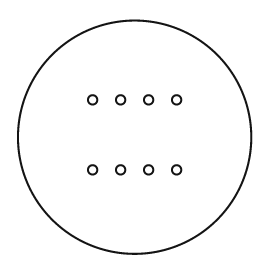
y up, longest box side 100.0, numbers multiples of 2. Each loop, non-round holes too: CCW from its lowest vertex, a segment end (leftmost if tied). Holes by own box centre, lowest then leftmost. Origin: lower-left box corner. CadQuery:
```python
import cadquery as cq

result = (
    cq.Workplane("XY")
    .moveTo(50.0, 50.0)
    .circle(50.0)
    .moveTo(32.0, 36.0)
    .circle(2.0)
    .moveTo(44.0, 36.0)
    .circle(2.0)
    .moveTo(56.0, 36.0)
    .circle(2.0)
    .moveTo(68.0, 36.0)
    .circle(2.0)
    .moveTo(32.0, 66.0)
    .circle(2.0)
    .moveTo(44.0, 66.0)
    .circle(2.0)
    .moveTo(56.0, 66.0)
    .circle(2.0)
    .moveTo(68.0, 66.0)
    .circle(2.0)
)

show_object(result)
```